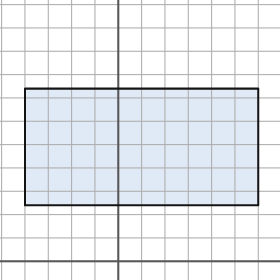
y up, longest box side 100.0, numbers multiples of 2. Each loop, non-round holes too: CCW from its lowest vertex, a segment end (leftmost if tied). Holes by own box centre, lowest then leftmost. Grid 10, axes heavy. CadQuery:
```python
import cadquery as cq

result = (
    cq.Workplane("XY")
    .moveTo(-40.0, 24.0)
    .lineTo(60.0, 24.0)
    .lineTo(60.0, 74.0)
    .lineTo(-40.0, 74.0)
    .close()
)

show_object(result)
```